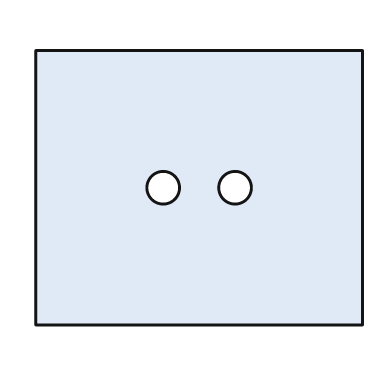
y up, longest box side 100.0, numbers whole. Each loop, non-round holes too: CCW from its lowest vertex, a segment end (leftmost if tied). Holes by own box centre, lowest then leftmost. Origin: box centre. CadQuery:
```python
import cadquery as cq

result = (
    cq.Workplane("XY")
    .moveTo(-50.0, -42.0)
    .lineTo(50.0, -42.0)
    .lineTo(50.0, 42.0)
    .lineTo(-50.0, 42.0)
    .close()
    .moveTo(-11.0, 0.0)
    .circle(5.0)
    .moveTo(11.0, 0.0)
    .circle(5.0)
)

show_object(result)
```